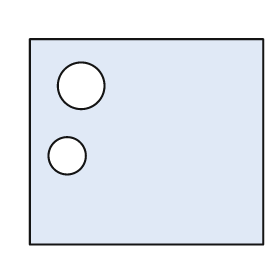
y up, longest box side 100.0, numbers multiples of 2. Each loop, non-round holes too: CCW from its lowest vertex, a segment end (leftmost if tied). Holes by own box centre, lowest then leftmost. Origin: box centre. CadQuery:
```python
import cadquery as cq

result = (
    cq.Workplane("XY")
    .moveTo(-50.0, -44.0)
    .lineTo(50.0, -44.0)
    .lineTo(50.0, 44.0)
    .lineTo(-50.0, 44.0)
    .close()
    .moveTo(-34.0, -6.0)
    .circle(8.0)
    .moveTo(-28.0, 24.0)
    .circle(10.0)
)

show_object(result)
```